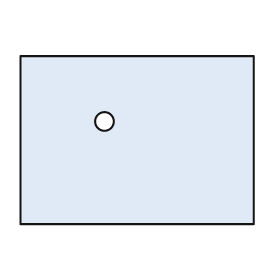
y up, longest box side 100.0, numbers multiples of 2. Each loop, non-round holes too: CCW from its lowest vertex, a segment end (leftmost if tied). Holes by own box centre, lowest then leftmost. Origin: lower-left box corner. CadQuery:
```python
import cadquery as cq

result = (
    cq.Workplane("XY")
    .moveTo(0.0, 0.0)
    .lineTo(100.0, 0.0)
    .lineTo(100.0, 72.0)
    .lineTo(0.0, 72.0)
    .close()
    .moveTo(36.0, 44.0)
    .circle(4.0)
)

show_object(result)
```